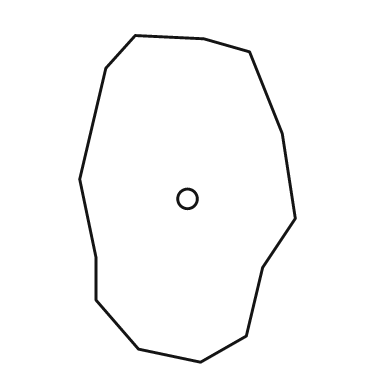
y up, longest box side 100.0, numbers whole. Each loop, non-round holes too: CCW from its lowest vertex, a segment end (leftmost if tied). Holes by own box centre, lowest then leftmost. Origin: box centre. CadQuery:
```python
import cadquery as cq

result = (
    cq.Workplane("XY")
    .moveTo(4.0, -50.0)
    .lineTo(18.0, -42.0)
    .lineTo(23.0, -21.0)
    .lineTo(33.0, -6.0)
    .lineTo(29.0, 20.0)
    .lineTo(19.0, 45.0)
    .lineTo(5.0, 49.0)
    .lineTo(-16.0, 50.0)
    .lineTo(-25.0, 40.0)
    .lineTo(-33.0, 6.0)
    .lineTo(-28.0, -18.0)
    .lineTo(-28.0, -31.0)
    .lineTo(-15.0, -46.0)
    .close()
    .moveTo(0.0, 0.0)
    .circle(3.0)
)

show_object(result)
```